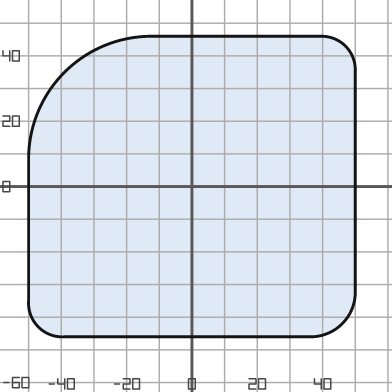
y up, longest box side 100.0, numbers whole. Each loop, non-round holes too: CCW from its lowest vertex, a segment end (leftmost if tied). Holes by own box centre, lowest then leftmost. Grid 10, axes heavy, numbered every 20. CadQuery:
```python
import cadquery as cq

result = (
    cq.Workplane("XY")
    .moveTo(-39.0, -46.0)
    .lineTo(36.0, -46.0)
    .threePointArc((46.0, -42.0), (50.0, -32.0))
    .lineTo(50.0, 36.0)
    .threePointArc((47.0, 43.0), (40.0, 46.0))
    .lineTo(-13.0, 46.0)
    .threePointArc((-39.0, 35.0), (-50.0, 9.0))
    .lineTo(-50.0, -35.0)
    .threePointArc((-47.0, -43.0), (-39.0, -46.0))
    .close()
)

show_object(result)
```